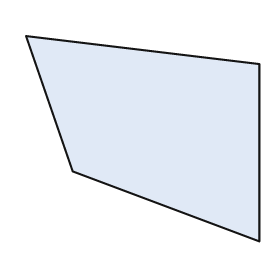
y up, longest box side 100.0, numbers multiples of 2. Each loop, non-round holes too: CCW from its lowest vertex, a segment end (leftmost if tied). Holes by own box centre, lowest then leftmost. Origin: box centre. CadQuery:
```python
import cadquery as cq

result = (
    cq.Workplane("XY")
    .moveTo(50.0, -44.0)
    .lineTo(50.0, 32.0)
    .lineTo(-50.0, 44.0)
    .lineTo(-30.0, -14.0)
    .close()
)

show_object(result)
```